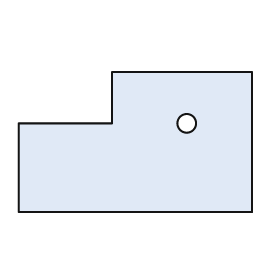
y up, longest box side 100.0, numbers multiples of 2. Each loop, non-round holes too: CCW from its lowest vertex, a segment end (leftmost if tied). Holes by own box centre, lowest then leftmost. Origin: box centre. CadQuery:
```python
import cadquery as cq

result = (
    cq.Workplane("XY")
    .moveTo(-50.0, -30.0)
    .lineTo(50.0, -30.0)
    .lineTo(50.0, 30.0)
    .lineTo(-10.0, 30.0)
    .lineTo(-10.0, 8.0)
    .lineTo(-50.0, 8.0)
    .close()
    .moveTo(22.0, 8.0)
    .circle(4.0)
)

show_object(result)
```